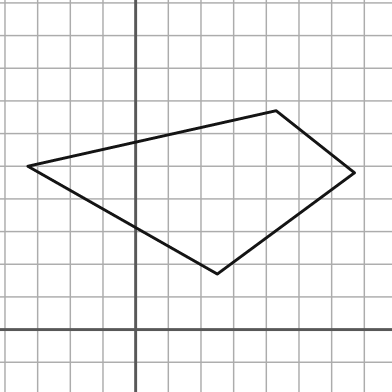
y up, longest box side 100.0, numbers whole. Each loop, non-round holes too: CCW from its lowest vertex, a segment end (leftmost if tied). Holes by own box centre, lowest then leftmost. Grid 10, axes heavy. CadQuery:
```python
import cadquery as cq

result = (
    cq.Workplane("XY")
    .moveTo(25.0, 17.0)
    .lineTo(67.0, 48.0)
    .lineTo(43.0, 67.0)
    .lineTo(-33.0, 50.0)
    .close()
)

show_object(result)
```